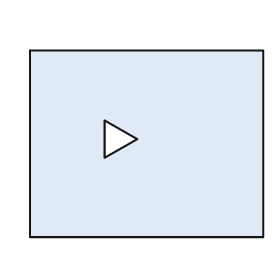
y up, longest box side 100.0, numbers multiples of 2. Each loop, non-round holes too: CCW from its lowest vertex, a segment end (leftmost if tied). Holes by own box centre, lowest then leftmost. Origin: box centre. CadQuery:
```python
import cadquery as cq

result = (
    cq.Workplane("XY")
    .moveTo(-50.0, -40.0)
    .lineTo(50.0, -40.0)
    .lineTo(50.0, 40.0)
    .lineTo(-50.0, 40.0)
    .close()
    .moveTo(-18.0, -6.0)
    .lineTo(-4.0, 2.0)
    .lineTo(-18.0, 10.0)
    .close()
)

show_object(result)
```